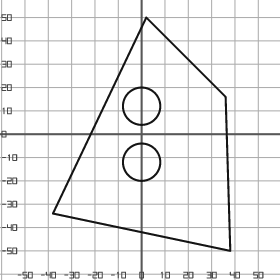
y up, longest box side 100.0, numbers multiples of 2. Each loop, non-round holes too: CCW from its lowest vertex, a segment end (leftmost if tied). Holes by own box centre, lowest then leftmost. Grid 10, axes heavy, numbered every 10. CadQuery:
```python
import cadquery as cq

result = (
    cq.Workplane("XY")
    .moveTo(38.0, -50.0)
    .lineTo(36.0, 16.0)
    .lineTo(2.0, 50.0)
    .lineTo(-38.0, -34.0)
    .close()
    .moveTo(0.0, -12.0)
    .circle(8.0)
    .moveTo(0.0, 12.0)
    .circle(8.0)
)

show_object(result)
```